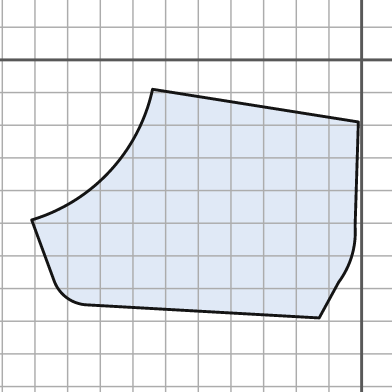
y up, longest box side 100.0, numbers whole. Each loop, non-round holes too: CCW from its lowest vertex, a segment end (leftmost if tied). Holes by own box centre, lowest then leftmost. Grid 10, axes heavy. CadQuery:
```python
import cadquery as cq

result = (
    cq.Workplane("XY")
    .moveTo(-13.0, -79.0)
    .lineTo(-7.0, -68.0)
    .threePointArc((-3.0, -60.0), (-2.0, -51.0))
    .lineTo(-1.0, -19.0)
    .lineTo(-64.0, -9.0)
    .threePointArc((-77.0, -34.0), (-101.0, -49.0))
    .lineTo(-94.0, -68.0)
    .threePointArc((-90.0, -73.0), (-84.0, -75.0))
    .close()
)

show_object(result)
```